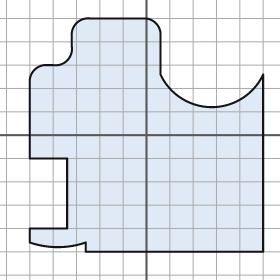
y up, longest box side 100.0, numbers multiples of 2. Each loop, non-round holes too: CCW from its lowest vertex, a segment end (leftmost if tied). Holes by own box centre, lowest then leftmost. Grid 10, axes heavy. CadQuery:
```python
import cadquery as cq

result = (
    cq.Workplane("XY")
    .moveTo(-26.0, -50.0)
    .lineTo(50.0, -50.0)
    .lineTo(50.0, 26.0)
    .threePointArc((28.0, 12.0), (6.0, 26.0))
    .lineTo(6.0, 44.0)
    .threePointArc((4.0, 48.0), (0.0, 50.0))
    .lineTo(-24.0, 50.0)
    .threePointArc((-30.0, 48.0), (-32.0, 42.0))
    .lineTo(-32.0, 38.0)
    .threePointArc((-34.0, 32.0), (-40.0, 30.0))
    .lineTo(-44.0, 30.0)
    .threePointArc((-48.0, 28.0), (-50.0, 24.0))
    .lineTo(-50.0, -10.0)
    .lineTo(-34.0, -10.0)
    .lineTo(-34.0, -40.0)
    .lineTo(-50.0, -40.0)
    .lineTo(-50.0, -46.0)
    .threePointArc((-38.0, -48.0), (-26.0, -46.0))
    .close()
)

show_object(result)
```